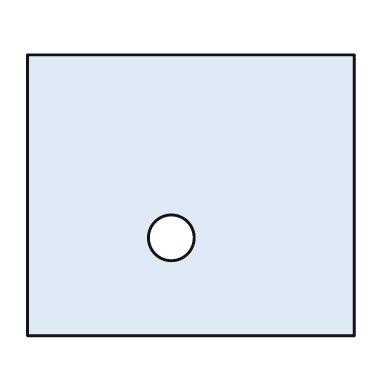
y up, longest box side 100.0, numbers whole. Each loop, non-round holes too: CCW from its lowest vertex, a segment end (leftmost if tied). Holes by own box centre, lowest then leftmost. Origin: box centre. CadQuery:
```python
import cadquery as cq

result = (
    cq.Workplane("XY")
    .moveTo(-50.0, -43.0)
    .lineTo(50.0, -43.0)
    .lineTo(50.0, 43.0)
    .lineTo(-50.0, 43.0)
    .close()
    .moveTo(-6.0, -13.0)
    .circle(7.0)
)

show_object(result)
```